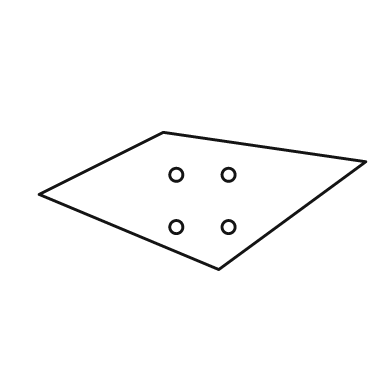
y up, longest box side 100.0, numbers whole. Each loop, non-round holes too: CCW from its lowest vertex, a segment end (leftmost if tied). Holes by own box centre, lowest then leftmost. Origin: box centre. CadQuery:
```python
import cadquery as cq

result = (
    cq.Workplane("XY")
    .moveTo(5.0, -21.0)
    .lineTo(50.0, 12.0)
    .lineTo(-12.0, 21.0)
    .lineTo(-50.0, 2.0)
    .close()
    .moveTo(-8.0, -8.0)
    .circle(2.0)
    .moveTo(8.0, -8.0)
    .circle(2.0)
    .moveTo(-8.0, 8.0)
    .circle(2.0)
    .moveTo(8.0, 8.0)
    .circle(2.0)
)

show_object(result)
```